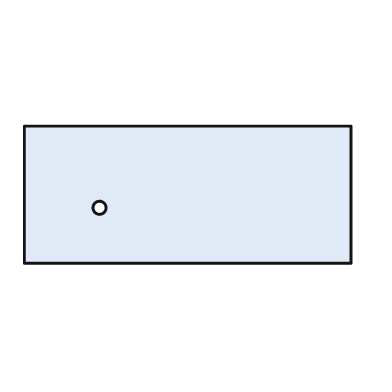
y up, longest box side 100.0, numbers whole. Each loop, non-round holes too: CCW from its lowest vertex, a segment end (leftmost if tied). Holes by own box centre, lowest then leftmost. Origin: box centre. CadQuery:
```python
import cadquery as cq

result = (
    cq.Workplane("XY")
    .moveTo(-50.0, -21.0)
    .lineTo(50.0, -21.0)
    .lineTo(50.0, 21.0)
    .lineTo(-50.0, 21.0)
    .close()
    .moveTo(-27.0, -4.0)
    .circle(2.0)
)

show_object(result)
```